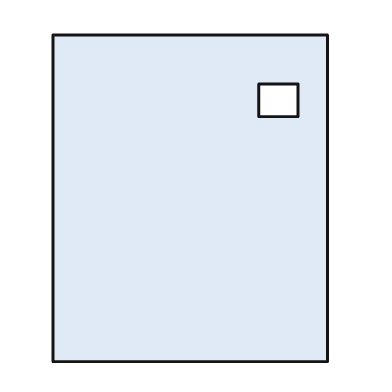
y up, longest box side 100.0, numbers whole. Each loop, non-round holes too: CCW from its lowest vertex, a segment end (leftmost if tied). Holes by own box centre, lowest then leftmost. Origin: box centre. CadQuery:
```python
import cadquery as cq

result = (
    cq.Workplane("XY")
    .moveTo(-42.0, -50.0)
    .lineTo(42.0, -50.0)
    .lineTo(42.0, 50.0)
    .lineTo(-42.0, 50.0)
    .close()
    .moveTo(21.0, 25.0)
    .lineTo(33.0, 25.0)
    .lineTo(33.0, 35.0)
    .lineTo(21.0, 35.0)
    .close()
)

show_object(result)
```